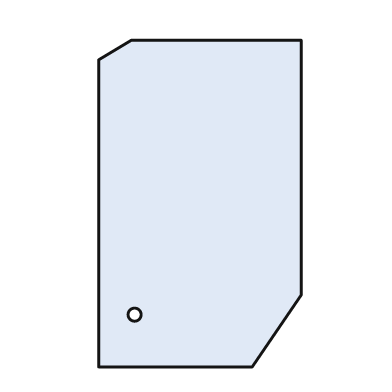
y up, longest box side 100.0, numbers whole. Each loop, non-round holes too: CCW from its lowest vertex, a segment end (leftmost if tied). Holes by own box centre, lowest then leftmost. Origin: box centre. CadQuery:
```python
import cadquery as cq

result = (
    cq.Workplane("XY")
    .moveTo(-31.0, -50.0)
    .lineTo(16.0, -50.0)
    .lineTo(31.0, -28.0)
    .lineTo(31.0, 50.0)
    .lineTo(-21.0, 50.0)
    .lineTo(-31.0, 44.0)
    .close()
    .moveTo(-20.0, -34.0)
    .circle(2.0)
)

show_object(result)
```